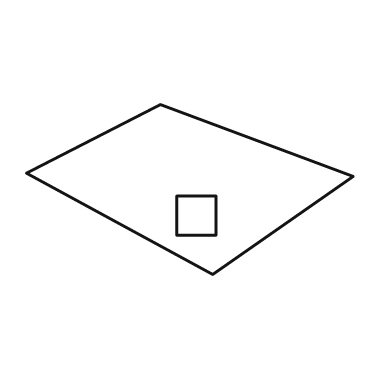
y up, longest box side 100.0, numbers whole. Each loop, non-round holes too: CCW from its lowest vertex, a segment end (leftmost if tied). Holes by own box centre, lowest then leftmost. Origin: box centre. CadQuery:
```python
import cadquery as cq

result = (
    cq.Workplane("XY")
    .moveTo(7.0, -26.0)
    .lineTo(50.0, 4.0)
    .lineTo(-9.0, 26.0)
    .lineTo(-50.0, 5.0)
    .close()
    .moveTo(-4.0, -14.0)
    .lineTo(8.0, -14.0)
    .lineTo(8.0, -2.0)
    .lineTo(-4.0, -2.0)
    .close()
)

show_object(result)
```